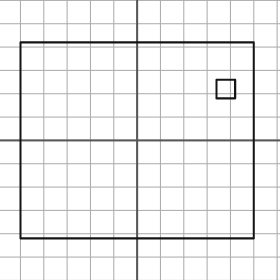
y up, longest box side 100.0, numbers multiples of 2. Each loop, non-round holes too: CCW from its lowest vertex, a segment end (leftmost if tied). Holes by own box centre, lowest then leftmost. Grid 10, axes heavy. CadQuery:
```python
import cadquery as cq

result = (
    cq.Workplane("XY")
    .moveTo(-50.0, -42.0)
    .lineTo(50.0, -42.0)
    .lineTo(50.0, 42.0)
    .lineTo(-50.0, 42.0)
    .close()
    .moveTo(34.0, 18.0)
    .lineTo(42.0, 18.0)
    .lineTo(42.0, 26.0)
    .lineTo(34.0, 26.0)
    .close()
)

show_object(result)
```